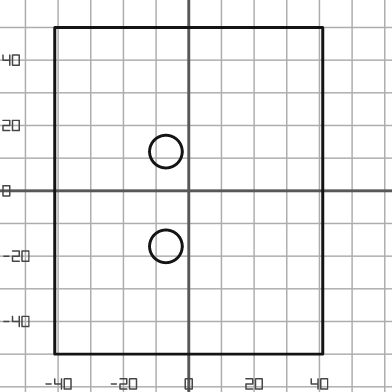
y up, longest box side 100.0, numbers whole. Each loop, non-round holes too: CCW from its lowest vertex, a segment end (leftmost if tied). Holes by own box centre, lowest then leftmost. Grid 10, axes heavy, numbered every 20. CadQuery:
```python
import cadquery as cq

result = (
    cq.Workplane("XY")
    .moveTo(-41.0, -50.0)
    .lineTo(41.0, -50.0)
    .lineTo(41.0, 50.0)
    .lineTo(-41.0, 50.0)
    .close()
    .moveTo(-7.0, -17.0)
    .circle(5.0)
    .moveTo(-7.0, 12.0)
    .circle(5.0)
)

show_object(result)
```